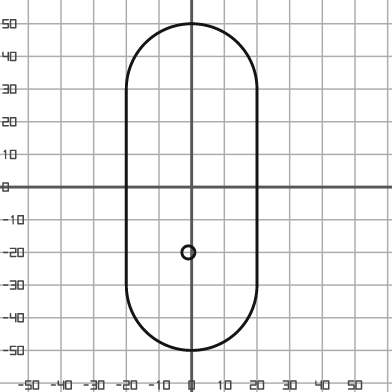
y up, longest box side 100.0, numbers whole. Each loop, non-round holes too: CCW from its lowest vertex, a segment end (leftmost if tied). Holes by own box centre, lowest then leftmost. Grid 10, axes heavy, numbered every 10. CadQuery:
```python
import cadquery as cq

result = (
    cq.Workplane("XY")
    .moveTo(-20.0, -30.0)
    .threePointArc((0.0, -50.0), (20.0, -30.0))
    .lineTo(20.0, 30.0)
    .threePointArc((0.0, 50.0), (-20.0, 30.0))
    .close()
    .moveTo(-1.0, -20.0)
    .circle(2.0)
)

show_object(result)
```